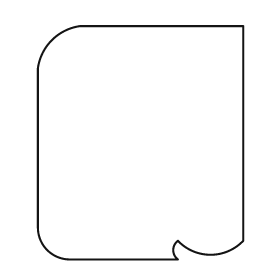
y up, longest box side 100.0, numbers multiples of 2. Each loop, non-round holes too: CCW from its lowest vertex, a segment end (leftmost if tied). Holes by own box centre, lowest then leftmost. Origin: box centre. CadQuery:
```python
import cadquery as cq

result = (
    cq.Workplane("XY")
    .moveTo(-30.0, -50.0)
    .lineTo(16.0, -50.0)
    .threePointArc((14.0, -46.0), (16.0, -42.0))
    .threePointArc((30.0, -48.0), (44.0, -42.0))
    .lineTo(44.0, 50.0)
    .lineTo(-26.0, 50.0)
    .threePointArc((-38.0, 44.0), (-44.0, 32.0))
    .lineTo(-44.0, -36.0)
    .threePointArc((-40.0, -46.0), (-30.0, -50.0))
    .close()
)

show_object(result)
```